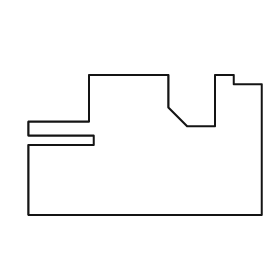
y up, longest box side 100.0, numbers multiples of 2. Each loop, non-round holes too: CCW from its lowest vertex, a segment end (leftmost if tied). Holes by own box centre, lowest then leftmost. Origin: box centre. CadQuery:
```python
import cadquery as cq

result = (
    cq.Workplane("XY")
    .moveTo(-50.0, -30.0)
    .lineTo(50.0, -30.0)
    .lineTo(50.0, 26.0)
    .lineTo(38.0, 26.0)
    .lineTo(38.0, 30.0)
    .lineTo(30.0, 30.0)
    .lineTo(30.0, 8.0)
    .lineTo(18.0, 8.0)
    .lineTo(10.0, 16.0)
    .lineTo(10.0, 30.0)
    .lineTo(-24.0, 30.0)
    .lineTo(-24.0, 10.0)
    .lineTo(-50.0, 10.0)
    .lineTo(-50.0, 4.0)
    .lineTo(-22.0, 4.0)
    .lineTo(-22.0, 0.0)
    .lineTo(-50.0, 0.0)
    .close()
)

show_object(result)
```